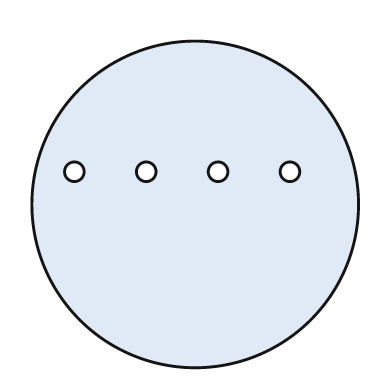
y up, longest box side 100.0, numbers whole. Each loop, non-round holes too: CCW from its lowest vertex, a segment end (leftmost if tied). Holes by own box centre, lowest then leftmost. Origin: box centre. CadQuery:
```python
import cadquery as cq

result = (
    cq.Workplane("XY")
    .moveTo(0.0, 0.0)
    .circle(50.0)
    .moveTo(-37.0, 10.0)
    .circle(3.0)
    .moveTo(-15.0, 10.0)
    .circle(3.0)
    .moveTo(7.0, 10.0)
    .circle(3.0)
    .moveTo(29.0, 10.0)
    .circle(3.0)
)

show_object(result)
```